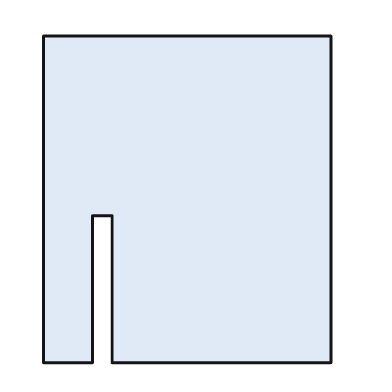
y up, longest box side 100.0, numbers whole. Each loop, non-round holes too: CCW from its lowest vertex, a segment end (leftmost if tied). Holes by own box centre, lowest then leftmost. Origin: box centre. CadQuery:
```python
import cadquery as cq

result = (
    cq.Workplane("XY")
    .moveTo(-44.0, -50.0)
    .lineTo(-29.0, -50.0)
    .lineTo(-29.0, -5.0)
    .lineTo(-23.0, -5.0)
    .lineTo(-23.0, -50.0)
    .lineTo(44.0, -50.0)
    .lineTo(44.0, 50.0)
    .lineTo(-44.0, 50.0)
    .close()
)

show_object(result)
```